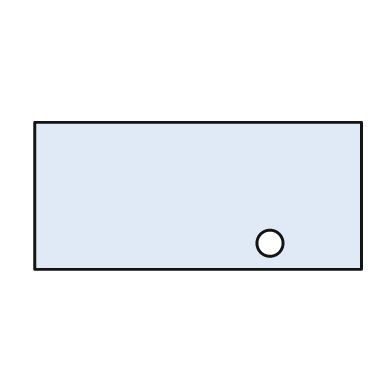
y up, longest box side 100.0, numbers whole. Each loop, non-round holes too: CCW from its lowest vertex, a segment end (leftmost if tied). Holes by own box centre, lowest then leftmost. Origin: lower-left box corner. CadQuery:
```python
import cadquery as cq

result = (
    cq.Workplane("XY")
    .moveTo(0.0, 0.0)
    .lineTo(100.0, 0.0)
    .lineTo(100.0, 45.0)
    .lineTo(0.0, 45.0)
    .close()
    .moveTo(72.0, 8.0)
    .circle(4.0)
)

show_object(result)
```